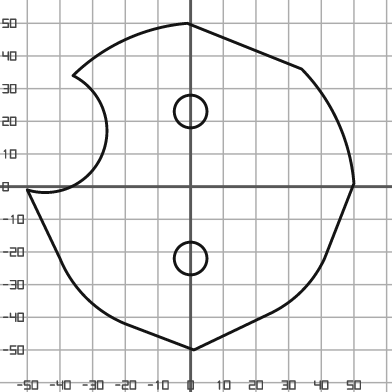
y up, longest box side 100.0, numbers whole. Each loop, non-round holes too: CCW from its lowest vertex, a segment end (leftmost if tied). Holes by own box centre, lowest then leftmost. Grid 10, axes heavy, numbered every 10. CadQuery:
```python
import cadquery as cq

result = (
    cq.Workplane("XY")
    .moveTo(1.0, -50.0)
    .lineTo(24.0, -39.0)
    .threePointArc((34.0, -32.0), (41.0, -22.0))
    .lineTo(50.0, 1.0)
    .threePointArc((45.0, 20.0), (34.0, 36.0))
    .lineTo(-1.0, 50.0)
    .threePointArc((-20.0, 45.0), (-36.0, 34.0))
    .threePointArc((-27.0, 10.0), (-50.0, -1.0))
    .lineTo(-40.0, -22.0)
    .threePointArc((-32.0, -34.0), (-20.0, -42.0))
    .close()
    .moveTo(0.0, -22.0)
    .circle(5.0)
    .moveTo(0.0, 23.0)
    .circle(5.0)
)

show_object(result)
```